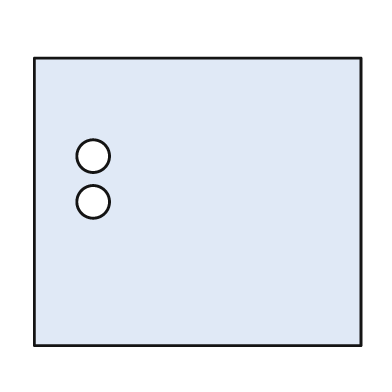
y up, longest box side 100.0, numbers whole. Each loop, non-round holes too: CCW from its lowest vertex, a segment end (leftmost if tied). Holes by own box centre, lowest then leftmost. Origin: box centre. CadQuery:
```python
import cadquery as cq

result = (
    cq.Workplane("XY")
    .moveTo(-50.0, -44.0)
    .lineTo(50.0, -44.0)
    .lineTo(50.0, 44.0)
    .lineTo(-50.0, 44.0)
    .close()
    .moveTo(-32.0, 0.0)
    .circle(5.0)
    .moveTo(-32.0, 14.0)
    .circle(5.0)
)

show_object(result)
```